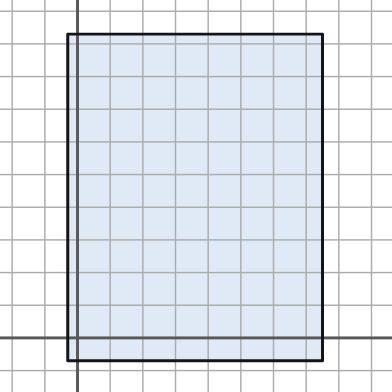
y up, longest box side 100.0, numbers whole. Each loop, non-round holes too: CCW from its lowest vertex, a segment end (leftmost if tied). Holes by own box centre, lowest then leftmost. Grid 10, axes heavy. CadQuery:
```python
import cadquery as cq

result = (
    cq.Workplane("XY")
    .moveTo(-3.0, -7.0)
    .lineTo(75.0, -7.0)
    .lineTo(75.0, 93.0)
    .lineTo(-3.0, 93.0)
    .close()
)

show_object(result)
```